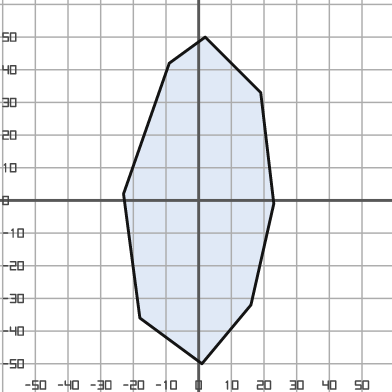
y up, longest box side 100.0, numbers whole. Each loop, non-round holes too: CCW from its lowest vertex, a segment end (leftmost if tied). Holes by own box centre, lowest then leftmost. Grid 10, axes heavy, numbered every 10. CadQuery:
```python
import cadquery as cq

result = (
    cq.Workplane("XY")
    .moveTo(1.0, -50.0)
    .lineTo(16.0, -32.0)
    .lineTo(23.0, -1.0)
    .lineTo(19.0, 33.0)
    .lineTo(2.0, 50.0)
    .lineTo(-9.0, 42.0)
    .lineTo(-23.0, 2.0)
    .lineTo(-18.0, -36.0)
    .close()
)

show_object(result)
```